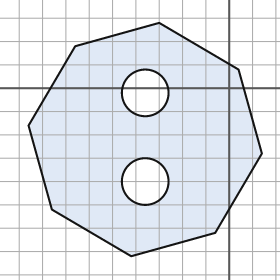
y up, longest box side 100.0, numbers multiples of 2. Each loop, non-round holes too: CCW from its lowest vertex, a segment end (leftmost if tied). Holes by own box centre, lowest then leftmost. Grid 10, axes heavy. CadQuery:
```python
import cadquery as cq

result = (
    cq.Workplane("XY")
    .moveTo(-42.0, -72.0)
    .lineTo(-6.0, -62.0)
    .lineTo(14.0, -28.0)
    .lineTo(4.0, 8.0)
    .lineTo(-30.0, 28.0)
    .lineTo(-66.0, 18.0)
    .lineTo(-86.0, -16.0)
    .lineTo(-76.0, -52.0)
    .close()
    .moveTo(-36.0, -40.0)
    .circle(10.0)
    .moveTo(-36.0, -2.0)
    .circle(10.0)
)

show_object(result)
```